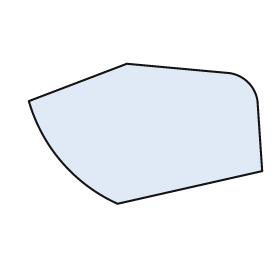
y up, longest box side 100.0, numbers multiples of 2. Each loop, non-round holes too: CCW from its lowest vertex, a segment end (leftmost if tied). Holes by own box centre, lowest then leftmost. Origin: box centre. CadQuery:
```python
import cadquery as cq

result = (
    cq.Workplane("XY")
    .moveTo(-12.0, -30.0)
    .lineTo(50.0, -16.0)
    .lineTo(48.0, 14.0)
    .threePointArc((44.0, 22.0), (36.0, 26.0))
    .lineTo(-8.0, 30.0)
    .lineTo(-50.0, 14.0)
    .threePointArc((-36.0, -12.0), (-12.0, -30.0))
    .close()
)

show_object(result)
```